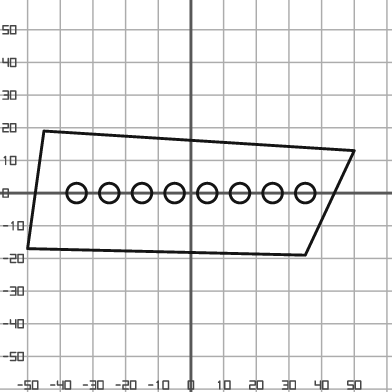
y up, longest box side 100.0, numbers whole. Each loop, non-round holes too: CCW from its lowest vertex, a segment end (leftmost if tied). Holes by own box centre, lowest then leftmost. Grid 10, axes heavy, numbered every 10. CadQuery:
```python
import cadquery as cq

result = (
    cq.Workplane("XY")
    .moveTo(35.0, -19.0)
    .lineTo(50.0, 13.0)
    .lineTo(-45.0, 19.0)
    .lineTo(-50.0, -17.0)
    .close()
    .moveTo(-35.0, 0.0)
    .circle(3.0)
    .moveTo(-25.0, 0.0)
    .circle(3.0)
    .moveTo(-15.0, 0.0)
    .circle(3.0)
    .moveTo(-5.0, 0.0)
    .circle(3.0)
    .moveTo(5.0, 0.0)
    .circle(3.0)
    .moveTo(15.0, 0.0)
    .circle(3.0)
    .moveTo(25.0, 0.0)
    .circle(3.0)
    .moveTo(35.0, 0.0)
    .circle(3.0)
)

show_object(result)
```